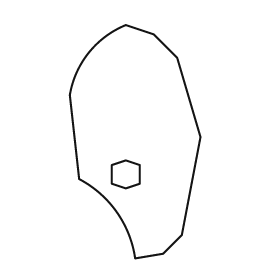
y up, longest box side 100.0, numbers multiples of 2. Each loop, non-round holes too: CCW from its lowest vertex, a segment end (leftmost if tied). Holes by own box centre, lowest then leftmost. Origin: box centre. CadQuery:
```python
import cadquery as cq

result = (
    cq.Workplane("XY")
    .moveTo(0.0, -50.0)
    .lineTo(12.0, -48.0)
    .lineTo(20.0, -40.0)
    .lineTo(28.0, 2.0)
    .lineTo(18.0, 36.0)
    .lineTo(8.0, 46.0)
    .lineTo(-4.0, 50.0)
    .threePointArc((-20.0, 38.0), (-28.0, 20.0))
    .lineTo(-24.0, -16.0)
    .threePointArc((-8.0, -30.0), (0.0, -50.0))
    .close()
    .moveTo(-4.0, -20.0)
    .lineTo(2.0, -18.0)
    .lineTo(2.0, -10.0)
    .lineTo(-4.0, -8.0)
    .lineTo(-10.0, -10.0)
    .lineTo(-10.0, -18.0)
    .close()
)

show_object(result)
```